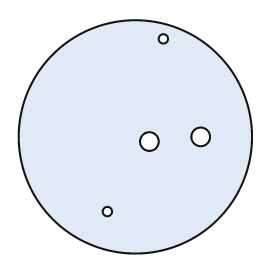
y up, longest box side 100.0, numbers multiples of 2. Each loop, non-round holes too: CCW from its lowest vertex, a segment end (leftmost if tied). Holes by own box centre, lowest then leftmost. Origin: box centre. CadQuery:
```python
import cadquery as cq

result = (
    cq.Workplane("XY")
    .moveTo(0.0, 0.0)
    .circle(50.0)
    .moveTo(-12.0, -32.0)
    .circle(2.0)
    .moveTo(6.0, -2.0)
    .circle(4.0)
    .moveTo(28.0, 0.0)
    .circle(4.0)
    .moveTo(12.0, 42.0)
    .circle(2.0)
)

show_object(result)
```